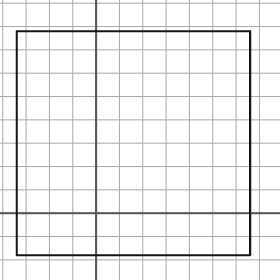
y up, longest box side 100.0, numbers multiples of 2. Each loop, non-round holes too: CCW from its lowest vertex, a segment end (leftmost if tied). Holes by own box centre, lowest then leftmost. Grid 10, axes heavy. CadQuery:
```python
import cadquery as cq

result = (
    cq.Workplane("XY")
    .moveTo(-34.0, -18.0)
    .lineTo(66.0, -18.0)
    .lineTo(66.0, 78.0)
    .lineTo(-34.0, 78.0)
    .close()
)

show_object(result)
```